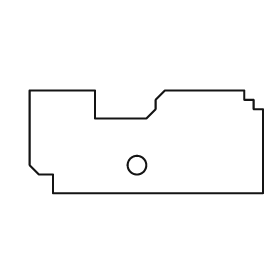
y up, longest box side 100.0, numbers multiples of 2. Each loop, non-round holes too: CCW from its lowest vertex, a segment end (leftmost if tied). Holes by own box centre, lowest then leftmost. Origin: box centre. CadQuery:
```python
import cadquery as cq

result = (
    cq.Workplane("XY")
    .moveTo(-40.0, -22.0)
    .lineTo(50.0, -22.0)
    .lineTo(50.0, 14.0)
    .lineTo(46.0, 14.0)
    .lineTo(46.0, 18.0)
    .lineTo(42.0, 18.0)
    .lineTo(42.0, 22.0)
    .lineTo(8.0, 22.0)
    .lineTo(4.0, 18.0)
    .lineTo(4.0, 14.0)
    .lineTo(0.0, 10.0)
    .lineTo(-22.0, 10.0)
    .lineTo(-22.0, 22.0)
    .lineTo(-50.0, 22.0)
    .lineTo(-50.0, -10.0)
    .lineTo(-46.0, -14.0)
    .lineTo(-40.0, -14.0)
    .close()
    .moveTo(-4.0, -10.0)
    .circle(4.0)
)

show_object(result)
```